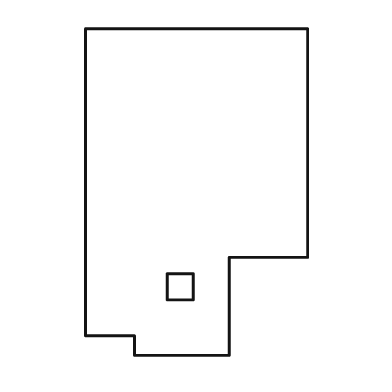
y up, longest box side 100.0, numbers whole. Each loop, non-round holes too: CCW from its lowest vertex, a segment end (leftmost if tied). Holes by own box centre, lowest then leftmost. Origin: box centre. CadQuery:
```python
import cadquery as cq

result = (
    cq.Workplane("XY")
    .moveTo(-19.0, -50.0)
    .lineTo(10.0, -50.0)
    .lineTo(10.0, -20.0)
    .lineTo(34.0, -20.0)
    .lineTo(34.0, 50.0)
    .lineTo(-34.0, 50.0)
    .lineTo(-34.0, -44.0)
    .lineTo(-19.0, -44.0)
    .close()
    .moveTo(-9.0, -33.0)
    .lineTo(-1.0, -33.0)
    .lineTo(-1.0, -25.0)
    .lineTo(-9.0, -25.0)
    .close()
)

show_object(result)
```